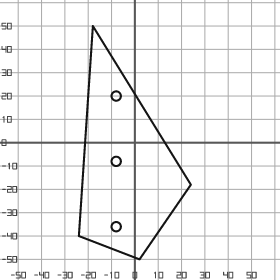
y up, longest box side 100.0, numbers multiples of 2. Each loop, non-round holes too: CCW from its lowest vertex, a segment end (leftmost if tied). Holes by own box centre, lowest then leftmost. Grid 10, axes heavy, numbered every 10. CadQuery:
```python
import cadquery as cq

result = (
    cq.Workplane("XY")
    .moveTo(2.0, -50.0)
    .lineTo(24.0, -18.0)
    .lineTo(-18.0, 50.0)
    .lineTo(-24.0, -40.0)
    .close()
    .moveTo(-8.0, -36.0)
    .circle(2.0)
    .moveTo(-8.0, -8.0)
    .circle(2.0)
    .moveTo(-8.0, 20.0)
    .circle(2.0)
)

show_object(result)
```